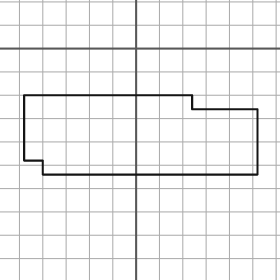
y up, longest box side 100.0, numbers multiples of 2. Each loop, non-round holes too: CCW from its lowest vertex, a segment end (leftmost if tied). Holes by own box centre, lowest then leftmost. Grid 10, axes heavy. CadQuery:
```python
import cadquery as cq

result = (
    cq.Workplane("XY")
    .moveTo(-40.0, -54.0)
    .lineTo(52.0, -54.0)
    .lineTo(52.0, -26.0)
    .lineTo(24.0, -26.0)
    .lineTo(24.0, -20.0)
    .lineTo(-48.0, -20.0)
    .lineTo(-48.0, -48.0)
    .lineTo(-40.0, -48.0)
    .close()
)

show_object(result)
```